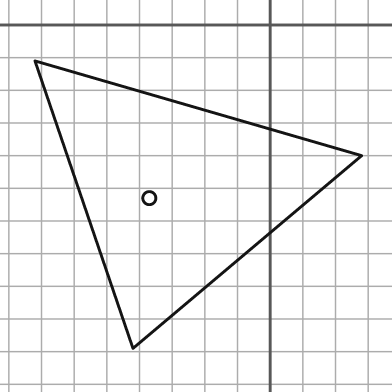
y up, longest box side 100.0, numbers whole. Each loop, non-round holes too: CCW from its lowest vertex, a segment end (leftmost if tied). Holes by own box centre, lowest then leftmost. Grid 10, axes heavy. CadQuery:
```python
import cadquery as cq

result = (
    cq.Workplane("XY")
    .moveTo(-42.0, -99.0)
    .lineTo(28.0, -40.0)
    .lineTo(-72.0, -11.0)
    .close()
    .moveTo(-37.0, -53.0)
    .circle(2.0)
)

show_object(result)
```